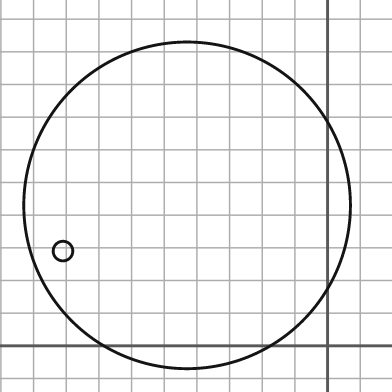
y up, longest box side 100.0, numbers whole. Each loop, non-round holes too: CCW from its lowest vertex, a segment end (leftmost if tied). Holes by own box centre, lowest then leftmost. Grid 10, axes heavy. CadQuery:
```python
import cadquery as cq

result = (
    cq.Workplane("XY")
    .moveTo(-43.0, 43.0)
    .circle(50.0)
    .moveTo(-81.0, 29.0)
    .circle(3.0)
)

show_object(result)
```